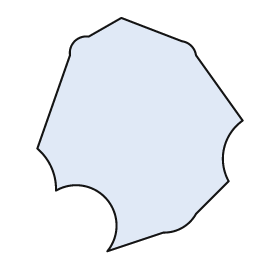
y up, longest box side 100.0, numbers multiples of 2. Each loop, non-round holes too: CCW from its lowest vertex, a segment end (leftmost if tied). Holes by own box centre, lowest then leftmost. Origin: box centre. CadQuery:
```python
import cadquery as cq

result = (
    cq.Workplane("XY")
    .moveTo(-14.0, -50.0)
    .lineTo(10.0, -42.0)
    .threePointArc((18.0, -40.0), (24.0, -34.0))
    .lineTo(38.0, -20.0)
    .threePointArc((36.0, -6.0), (44.0, 6.0))
    .lineTo(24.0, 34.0)
    .threePointArc((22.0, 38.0), (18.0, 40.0))
    .lineTo(-8.0, 50.0)
    .lineTo(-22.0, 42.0)
    .threePointArc((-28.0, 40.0), (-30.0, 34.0))
    .lineTo(-44.0, -6.0)
    .threePointArc((-38.0, -14.0), (-36.0, -24.0))
    .threePointArc((-14.0, -28.0), (-14.0, -50.0))
    .close()
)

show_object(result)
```